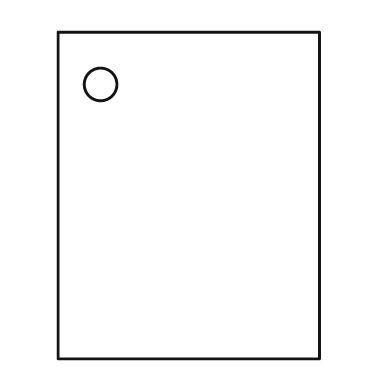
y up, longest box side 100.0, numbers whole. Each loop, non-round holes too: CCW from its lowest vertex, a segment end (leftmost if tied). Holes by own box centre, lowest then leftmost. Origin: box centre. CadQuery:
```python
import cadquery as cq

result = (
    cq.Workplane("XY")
    .moveTo(-40.0, -50.0)
    .lineTo(40.0, -50.0)
    .lineTo(40.0, 50.0)
    .lineTo(-40.0, 50.0)
    .close()
    .moveTo(-27.0, 34.0)
    .circle(5.0)
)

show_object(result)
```